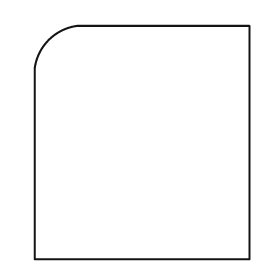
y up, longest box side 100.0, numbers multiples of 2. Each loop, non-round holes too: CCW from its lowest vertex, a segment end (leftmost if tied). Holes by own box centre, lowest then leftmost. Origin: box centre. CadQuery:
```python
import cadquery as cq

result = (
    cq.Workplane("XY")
    .moveTo(-46.0, -50.0)
    .lineTo(46.0, -50.0)
    .lineTo(46.0, 50.0)
    .lineTo(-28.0, 50.0)
    .threePointArc((-40.0, 44.0), (-46.0, 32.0))
    .close()
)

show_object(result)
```